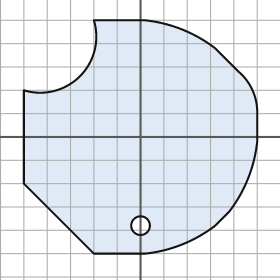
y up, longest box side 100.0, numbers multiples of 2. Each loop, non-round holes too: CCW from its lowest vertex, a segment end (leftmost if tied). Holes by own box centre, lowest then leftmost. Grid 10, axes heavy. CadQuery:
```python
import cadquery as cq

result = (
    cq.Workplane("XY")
    .moveTo(-20.0, -50.0)
    .lineTo(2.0, -50.0)
    .threePointArc((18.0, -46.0), (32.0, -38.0))
    .lineTo(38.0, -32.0)
    .threePointArc((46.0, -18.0), (50.0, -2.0))
    .lineTo(50.0, 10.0)
    .threePointArc((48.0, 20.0), (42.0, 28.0))
    .lineTo(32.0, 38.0)
    .threePointArc((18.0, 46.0), (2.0, 50.0))
    .lineTo(-20.0, 50.0)
    .threePointArc((-26.0, 26.0), (-50.0, 20.0))
    .lineTo(-50.0, -20.0)
    .close()
    .moveTo(0.0, -38.0)
    .circle(4.0)
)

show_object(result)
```